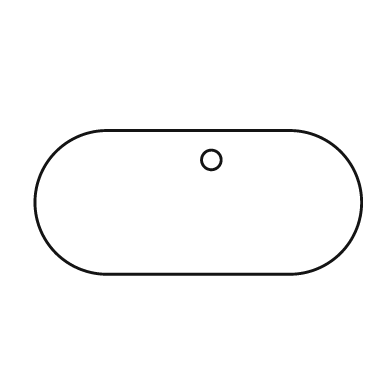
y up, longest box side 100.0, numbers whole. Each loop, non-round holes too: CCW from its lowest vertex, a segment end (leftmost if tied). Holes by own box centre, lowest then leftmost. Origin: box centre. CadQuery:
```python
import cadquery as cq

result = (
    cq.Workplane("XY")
    .moveTo(-28.0, -22.0)
    .lineTo(28.0, -22.0)
    .threePointArc((50.0, 0.0), (28.0, 22.0))
    .lineTo(-28.0, 22.0)
    .threePointArc((-50.0, 0.0), (-28.0, -22.0))
    .close()
    .moveTo(4.0, 13.0)
    .circle(3.0)
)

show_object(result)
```